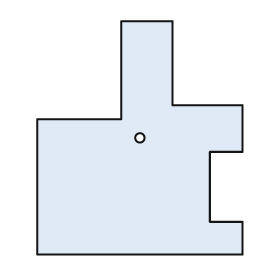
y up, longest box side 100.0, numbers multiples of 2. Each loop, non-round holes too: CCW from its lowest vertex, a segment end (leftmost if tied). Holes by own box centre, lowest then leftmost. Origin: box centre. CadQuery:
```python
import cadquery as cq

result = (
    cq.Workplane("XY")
    .moveTo(-44.0, -50.0)
    .lineTo(44.0, -50.0)
    .lineTo(44.0, -36.0)
    .lineTo(30.0, -36.0)
    .lineTo(30.0, -6.0)
    .lineTo(44.0, -6.0)
    .lineTo(44.0, 14.0)
    .lineTo(14.0, 14.0)
    .lineTo(14.0, 50.0)
    .lineTo(-8.0, 50.0)
    .lineTo(-8.0, 8.0)
    .lineTo(-44.0, 8.0)
    .close()
    .moveTo(0.0, 0.0)
    .circle(2.0)
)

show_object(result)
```